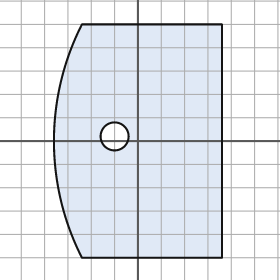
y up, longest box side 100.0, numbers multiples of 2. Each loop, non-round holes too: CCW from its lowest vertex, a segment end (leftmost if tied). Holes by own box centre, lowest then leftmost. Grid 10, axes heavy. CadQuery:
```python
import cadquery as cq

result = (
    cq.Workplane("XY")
    .moveTo(-24.0, -50.0)
    .lineTo(36.0, -50.0)
    .lineTo(36.0, 50.0)
    .lineTo(-24.0, 50.0)
    .threePointArc((-36.0, 0.0), (-24.0, -50.0))
    .close()
    .moveTo(-10.0, 2.0)
    .circle(6.0)
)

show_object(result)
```